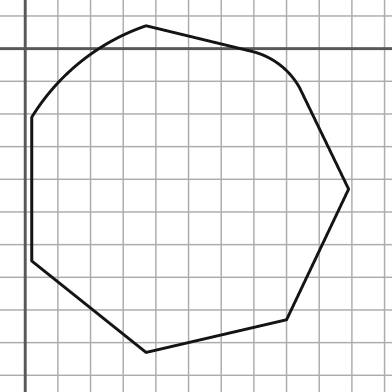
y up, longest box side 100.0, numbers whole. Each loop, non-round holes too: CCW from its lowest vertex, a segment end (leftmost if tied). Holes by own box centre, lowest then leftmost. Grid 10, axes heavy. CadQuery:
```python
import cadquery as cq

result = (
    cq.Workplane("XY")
    .moveTo(37.0, -93.0)
    .lineTo(80.0, -83.0)
    .lineTo(99.0, -43.0)
    .lineTo(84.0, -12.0)
    .threePointArc((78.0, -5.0), (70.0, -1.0))
    .lineTo(37.0, 7.0)
    .threePointArc((17.0, -4.0), (2.0, -21.0))
    .lineTo(2.0, -65.0)
    .close()
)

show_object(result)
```